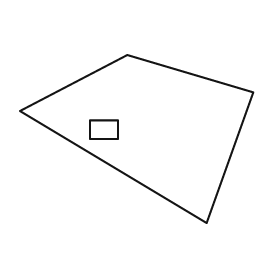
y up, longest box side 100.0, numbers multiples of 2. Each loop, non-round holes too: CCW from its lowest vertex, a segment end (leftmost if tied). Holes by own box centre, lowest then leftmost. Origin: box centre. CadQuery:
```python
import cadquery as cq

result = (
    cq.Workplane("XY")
    .moveTo(30.0, -36.0)
    .lineTo(50.0, 20.0)
    .lineTo(-4.0, 36.0)
    .lineTo(-50.0, 12.0)
    .close()
    .moveTo(-20.0, 0.0)
    .lineTo(-8.0, 0.0)
    .lineTo(-8.0, 8.0)
    .lineTo(-20.0, 8.0)
    .close()
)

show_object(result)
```